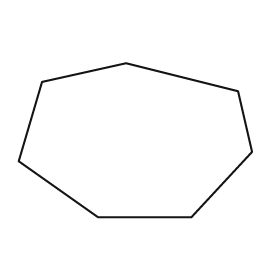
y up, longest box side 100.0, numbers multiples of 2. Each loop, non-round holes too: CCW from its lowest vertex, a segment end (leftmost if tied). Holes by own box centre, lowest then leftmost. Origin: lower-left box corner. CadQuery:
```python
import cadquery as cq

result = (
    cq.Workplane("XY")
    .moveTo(34.0, 0.0)
    .lineTo(74.0, 0.0)
    .lineTo(100.0, 28.0)
    .lineTo(94.0, 54.0)
    .lineTo(46.0, 66.0)
    .lineTo(10.0, 58.0)
    .lineTo(0.0, 24.0)
    .close()
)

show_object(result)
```